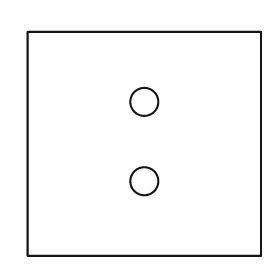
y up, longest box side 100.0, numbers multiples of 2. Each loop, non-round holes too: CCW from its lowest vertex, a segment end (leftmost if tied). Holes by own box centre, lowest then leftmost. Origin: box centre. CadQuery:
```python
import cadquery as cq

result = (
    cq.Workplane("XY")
    .moveTo(-50.0, -48.0)
    .lineTo(50.0, -48.0)
    .lineTo(50.0, 48.0)
    .lineTo(-50.0, 48.0)
    .close()
    .moveTo(0.0, -16.0)
    .circle(6.0)
    .moveTo(0.0, 18.0)
    .circle(6.0)
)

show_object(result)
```